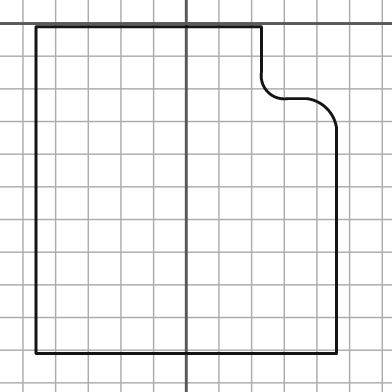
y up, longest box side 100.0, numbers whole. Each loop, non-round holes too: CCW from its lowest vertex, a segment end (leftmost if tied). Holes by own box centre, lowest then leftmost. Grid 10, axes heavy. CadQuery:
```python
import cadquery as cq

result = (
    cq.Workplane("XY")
    .moveTo(-46.0, -101.0)
    .lineTo(46.0, -101.0)
    .lineTo(46.0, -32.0)
    .threePointArc((43.0, -26.0), (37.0, -23.0))
    .lineTo(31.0, -23.0)
    .threePointArc((25.0, -21.0), (23.0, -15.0))
    .lineTo(23.0, -1.0)
    .lineTo(-46.0, -1.0)
    .close()
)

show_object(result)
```